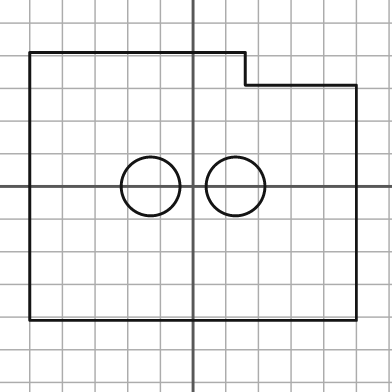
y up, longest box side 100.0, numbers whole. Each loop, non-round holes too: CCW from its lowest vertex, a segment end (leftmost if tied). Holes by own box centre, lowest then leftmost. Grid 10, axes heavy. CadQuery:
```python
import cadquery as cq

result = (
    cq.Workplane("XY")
    .moveTo(-50.0, -41.0)
    .lineTo(50.0, -41.0)
    .lineTo(50.0, 31.0)
    .lineTo(16.0, 31.0)
    .lineTo(16.0, 41.0)
    .lineTo(-50.0, 41.0)
    .close()
    .moveTo(-13.0, 0.0)
    .circle(9.0)
    .moveTo(13.0, 0.0)
    .circle(9.0)
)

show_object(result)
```